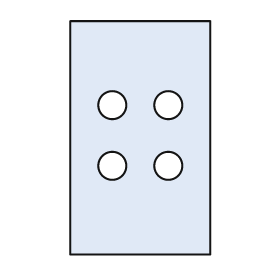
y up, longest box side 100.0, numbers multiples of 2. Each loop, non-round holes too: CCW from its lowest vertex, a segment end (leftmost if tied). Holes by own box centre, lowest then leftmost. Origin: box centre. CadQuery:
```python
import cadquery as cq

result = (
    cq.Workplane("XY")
    .moveTo(-30.0, -50.0)
    .lineTo(30.0, -50.0)
    .lineTo(30.0, 50.0)
    .lineTo(-30.0, 50.0)
    .close()
    .moveTo(-12.0, -12.0)
    .circle(6.0)
    .moveTo(12.0, -12.0)
    .circle(6.0)
    .moveTo(-12.0, 14.0)
    .circle(6.0)
    .moveTo(12.0, 14.0)
    .circle(6.0)
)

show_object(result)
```